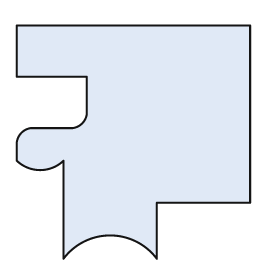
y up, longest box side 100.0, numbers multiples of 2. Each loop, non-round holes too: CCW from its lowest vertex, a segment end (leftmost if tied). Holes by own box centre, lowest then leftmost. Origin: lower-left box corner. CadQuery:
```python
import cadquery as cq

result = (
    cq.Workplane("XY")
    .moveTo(20.0, 0.0)
    .threePointArc((40.0, 10.0), (60.0, 0.0))
    .lineTo(60.0, 24.0)
    .lineTo(100.0, 24.0)
    .lineTo(100.0, 100.0)
    .lineTo(0.0, 100.0)
    .lineTo(0.0, 78.0)
    .lineTo(30.0, 78.0)
    .lineTo(30.0, 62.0)
    .threePointArc((28.0, 58.0), (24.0, 56.0))
    .lineTo(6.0, 56.0)
    .threePointArc((2.0, 54.0), (0.0, 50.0))
    .lineTo(0.0, 42.0)
    .threePointArc((10.0, 38.0), (20.0, 42.0))
    .close()
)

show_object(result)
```